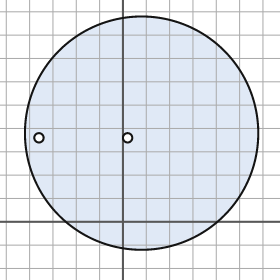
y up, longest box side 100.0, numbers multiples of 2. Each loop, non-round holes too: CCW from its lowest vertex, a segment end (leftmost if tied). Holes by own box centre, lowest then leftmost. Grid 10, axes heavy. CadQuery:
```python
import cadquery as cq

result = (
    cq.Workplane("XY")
    .moveTo(8.0, 38.0)
    .circle(50.0)
    .moveTo(-36.0, 36.0)
    .circle(2.0)
    .moveTo(2.0, 36.0)
    .circle(2.0)
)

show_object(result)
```